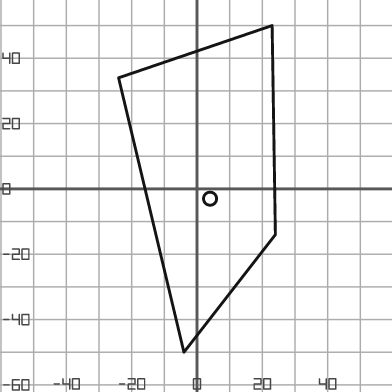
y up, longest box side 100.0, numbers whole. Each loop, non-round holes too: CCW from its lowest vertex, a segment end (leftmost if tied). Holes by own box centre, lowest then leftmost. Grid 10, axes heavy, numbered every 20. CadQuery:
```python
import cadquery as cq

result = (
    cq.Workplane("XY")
    .moveTo(-4.0, -50.0)
    .lineTo(24.0, -14.0)
    .lineTo(23.0, 50.0)
    .lineTo(-24.0, 34.0)
    .close()
    .moveTo(4.0, -3.0)
    .circle(2.0)
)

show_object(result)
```